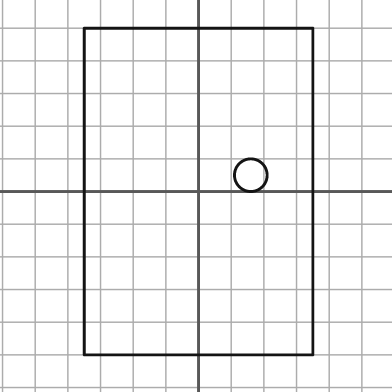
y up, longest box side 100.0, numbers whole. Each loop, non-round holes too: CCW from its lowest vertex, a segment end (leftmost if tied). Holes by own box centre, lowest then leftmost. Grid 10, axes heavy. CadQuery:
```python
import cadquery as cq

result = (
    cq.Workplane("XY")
    .moveTo(-35.0, -50.0)
    .lineTo(35.0, -50.0)
    .lineTo(35.0, 50.0)
    .lineTo(-35.0, 50.0)
    .close()
    .moveTo(16.0, 5.0)
    .circle(5.0)
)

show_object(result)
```